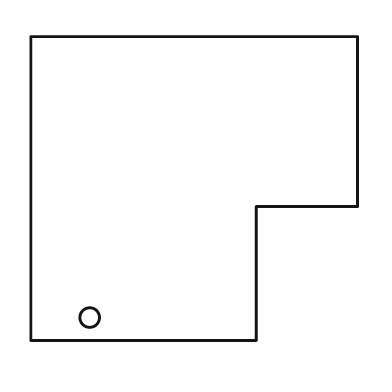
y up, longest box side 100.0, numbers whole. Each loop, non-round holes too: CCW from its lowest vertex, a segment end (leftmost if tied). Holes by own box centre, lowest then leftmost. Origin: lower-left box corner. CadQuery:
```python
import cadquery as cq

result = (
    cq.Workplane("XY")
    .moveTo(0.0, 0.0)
    .lineTo(69.0, 0.0)
    .lineTo(69.0, 41.0)
    .lineTo(100.0, 41.0)
    .lineTo(100.0, 93.0)
    .lineTo(0.0, 93.0)
    .close()
    .moveTo(18.0, 7.0)
    .circle(3.0)
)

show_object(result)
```